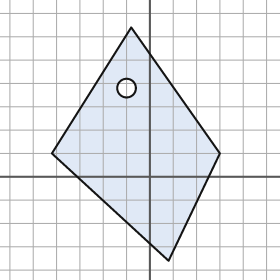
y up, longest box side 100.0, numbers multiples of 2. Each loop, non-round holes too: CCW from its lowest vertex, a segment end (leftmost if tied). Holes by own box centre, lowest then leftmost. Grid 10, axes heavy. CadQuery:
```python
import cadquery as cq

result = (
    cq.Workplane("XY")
    .moveTo(8.0, -36.0)
    .lineTo(30.0, 10.0)
    .lineTo(-8.0, 64.0)
    .lineTo(-42.0, 10.0)
    .close()
    .moveTo(-10.0, 38.0)
    .circle(4.0)
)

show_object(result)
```